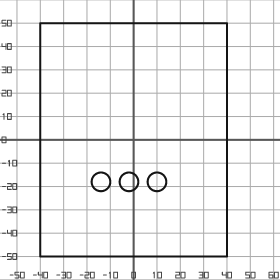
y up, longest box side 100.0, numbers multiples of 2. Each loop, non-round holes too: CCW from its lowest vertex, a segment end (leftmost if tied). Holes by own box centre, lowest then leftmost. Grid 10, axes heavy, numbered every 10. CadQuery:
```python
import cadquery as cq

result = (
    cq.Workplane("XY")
    .moveTo(-40.0, -50.0)
    .lineTo(40.0, -50.0)
    .lineTo(40.0, 50.0)
    .lineTo(-40.0, 50.0)
    .close()
    .moveTo(-14.0, -18.0)
    .circle(4.0)
    .moveTo(-2.0, -18.0)
    .circle(4.0)
    .moveTo(10.0, -18.0)
    .circle(4.0)
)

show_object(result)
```